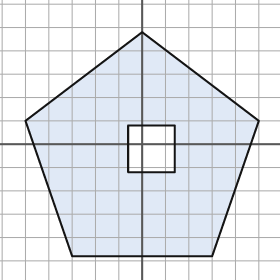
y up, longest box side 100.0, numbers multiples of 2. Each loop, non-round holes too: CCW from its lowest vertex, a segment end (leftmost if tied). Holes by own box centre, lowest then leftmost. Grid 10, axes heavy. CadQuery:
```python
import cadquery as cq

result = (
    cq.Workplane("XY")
    .moveTo(-30.0, -48.0)
    .lineTo(30.0, -48.0)
    .lineTo(50.0, 10.0)
    .lineTo(0.0, 48.0)
    .lineTo(-50.0, 10.0)
    .close()
    .moveTo(-6.0, -12.0)
    .lineTo(14.0, -12.0)
    .lineTo(14.0, 8.0)
    .lineTo(-6.0, 8.0)
    .close()
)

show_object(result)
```